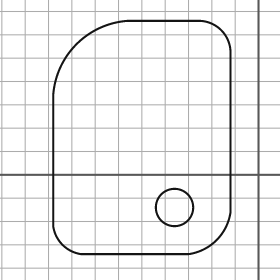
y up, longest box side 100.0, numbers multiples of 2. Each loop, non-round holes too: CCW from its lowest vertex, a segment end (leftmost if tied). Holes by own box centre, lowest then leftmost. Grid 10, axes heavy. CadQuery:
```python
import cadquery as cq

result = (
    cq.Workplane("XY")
    .moveTo(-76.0, -34.0)
    .lineTo(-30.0, -34.0)
    .threePointArc((-18.0, -28.0), (-12.0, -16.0))
    .lineTo(-12.0, 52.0)
    .threePointArc((-16.0, 62.0), (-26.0, 66.0))
    .lineTo(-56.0, 66.0)
    .threePointArc((-78.0, 56.0), (-88.0, 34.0))
    .lineTo(-88.0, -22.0)
    .threePointArc((-84.0, -30.0), (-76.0, -34.0))
    .close()
    .moveTo(-36.0, -14.0)
    .circle(8.0)
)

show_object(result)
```